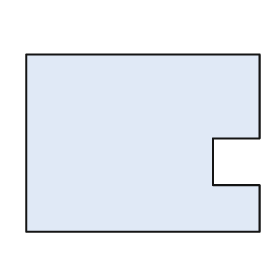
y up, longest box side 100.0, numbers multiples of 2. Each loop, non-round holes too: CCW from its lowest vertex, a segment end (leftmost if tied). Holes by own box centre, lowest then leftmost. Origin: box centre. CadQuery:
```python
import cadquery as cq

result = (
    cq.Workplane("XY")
    .moveTo(-50.0, -38.0)
    .lineTo(50.0, -38.0)
    .lineTo(50.0, -18.0)
    .lineTo(30.0, -18.0)
    .lineTo(30.0, 2.0)
    .lineTo(50.0, 2.0)
    .lineTo(50.0, 38.0)
    .lineTo(-50.0, 38.0)
    .close()
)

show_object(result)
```